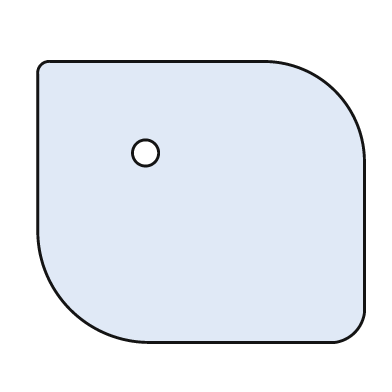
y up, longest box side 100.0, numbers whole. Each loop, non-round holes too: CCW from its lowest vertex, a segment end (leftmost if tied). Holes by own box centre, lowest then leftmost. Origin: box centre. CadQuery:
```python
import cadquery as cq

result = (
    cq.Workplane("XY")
    .moveTo(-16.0, -43.0)
    .lineTo(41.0, -43.0)
    .threePointArc((47.0, -40.0), (50.0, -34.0))
    .lineTo(50.0, 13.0)
    .threePointArc((41.0, 34.0), (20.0, 43.0))
    .lineTo(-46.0, 43.0)
    .threePointArc((-49.0, 42.0), (-50.0, 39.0))
    .lineTo(-50.0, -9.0)
    .threePointArc((-40.0, -33.0), (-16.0, -43.0))
    .close()
    .moveTo(-17.0, 15.0)
    .circle(4.0)
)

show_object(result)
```